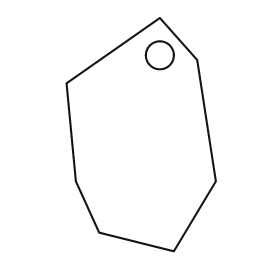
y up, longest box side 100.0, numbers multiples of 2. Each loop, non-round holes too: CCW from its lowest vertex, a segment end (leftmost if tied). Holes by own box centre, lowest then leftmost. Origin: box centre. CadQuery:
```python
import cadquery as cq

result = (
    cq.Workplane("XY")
    .moveTo(14.0, -50.0)
    .lineTo(32.0, -20.0)
    .lineTo(24.0, 32.0)
    .lineTo(8.0, 50.0)
    .lineTo(-32.0, 22.0)
    .lineTo(-28.0, -20.0)
    .lineTo(-18.0, -42.0)
    .close()
    .moveTo(8.0, 34.0)
    .circle(6.0)
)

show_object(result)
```